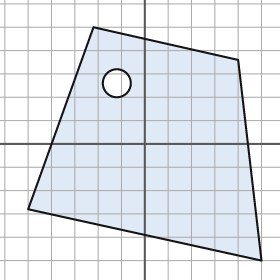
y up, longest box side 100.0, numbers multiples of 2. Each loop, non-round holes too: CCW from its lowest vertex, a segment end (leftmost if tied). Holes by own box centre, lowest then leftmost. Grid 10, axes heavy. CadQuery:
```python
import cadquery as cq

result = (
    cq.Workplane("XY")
    .moveTo(50.0, -50.0)
    .lineTo(40.0, 36.0)
    .lineTo(-22.0, 50.0)
    .lineTo(-50.0, -28.0)
    .close()
    .moveTo(-12.0, 26.0)
    .circle(6.0)
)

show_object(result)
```